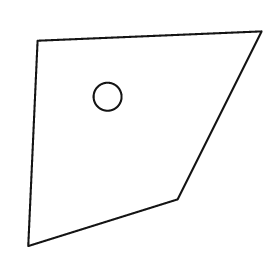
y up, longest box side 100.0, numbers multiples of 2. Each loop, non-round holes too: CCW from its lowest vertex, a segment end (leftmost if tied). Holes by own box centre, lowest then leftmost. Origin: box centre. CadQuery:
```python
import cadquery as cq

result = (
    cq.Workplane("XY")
    .moveTo(-50.0, -46.0)
    .lineTo(14.0, -26.0)
    .lineTo(50.0, 46.0)
    .lineTo(-46.0, 42.0)
    .close()
    .moveTo(-16.0, 18.0)
    .circle(6.0)
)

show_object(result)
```